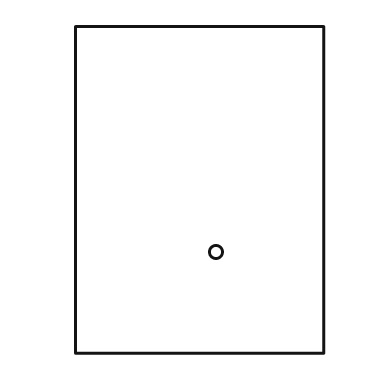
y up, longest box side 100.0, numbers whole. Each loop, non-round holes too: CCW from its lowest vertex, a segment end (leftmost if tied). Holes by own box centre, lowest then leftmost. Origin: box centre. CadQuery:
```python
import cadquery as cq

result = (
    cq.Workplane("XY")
    .moveTo(-38.0, -50.0)
    .lineTo(38.0, -50.0)
    .lineTo(38.0, 50.0)
    .lineTo(-38.0, 50.0)
    .close()
    .moveTo(5.0, -19.0)
    .circle(2.0)
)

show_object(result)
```